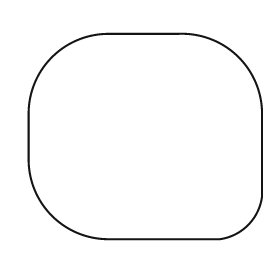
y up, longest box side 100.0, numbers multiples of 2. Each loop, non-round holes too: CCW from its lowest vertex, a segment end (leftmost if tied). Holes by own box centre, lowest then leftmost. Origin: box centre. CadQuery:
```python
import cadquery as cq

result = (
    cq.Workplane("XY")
    .moveTo(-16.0, -44.0)
    .lineTo(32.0, -44.0)
    .threePointArc((44.0, -38.0), (50.0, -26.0))
    .lineTo(50.0, 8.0)
    .threePointArc((40.0, 34.0), (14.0, 44.0))
    .lineTo(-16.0, 44.0)
    .threePointArc((-40.0, 34.0), (-50.0, 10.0))
    .lineTo(-50.0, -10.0)
    .threePointArc((-40.0, -34.0), (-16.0, -44.0))
    .close()
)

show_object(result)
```